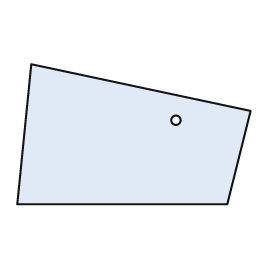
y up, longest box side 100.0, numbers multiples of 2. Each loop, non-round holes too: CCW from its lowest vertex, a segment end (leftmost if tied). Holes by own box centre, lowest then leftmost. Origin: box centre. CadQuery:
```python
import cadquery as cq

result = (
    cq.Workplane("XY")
    .moveTo(-50.0, -30.0)
    .lineTo(40.0, -30.0)
    .lineTo(50.0, 10.0)
    .lineTo(-44.0, 30.0)
    .close()
    .moveTo(18.0, 6.0)
    .circle(2.0)
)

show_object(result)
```